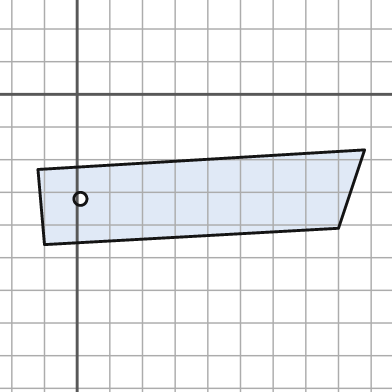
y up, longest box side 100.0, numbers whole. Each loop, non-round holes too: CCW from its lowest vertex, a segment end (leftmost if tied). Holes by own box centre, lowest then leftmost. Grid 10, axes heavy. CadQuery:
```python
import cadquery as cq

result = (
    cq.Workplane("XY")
    .moveTo(-10.0, -46.0)
    .lineTo(80.0, -41.0)
    .lineTo(88.0, -17.0)
    .lineTo(-12.0, -23.0)
    .close()
    .moveTo(1.0, -32.0)
    .circle(2.0)
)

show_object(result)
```